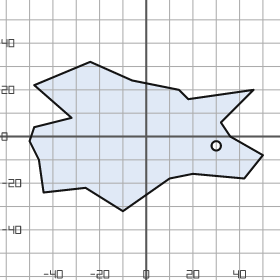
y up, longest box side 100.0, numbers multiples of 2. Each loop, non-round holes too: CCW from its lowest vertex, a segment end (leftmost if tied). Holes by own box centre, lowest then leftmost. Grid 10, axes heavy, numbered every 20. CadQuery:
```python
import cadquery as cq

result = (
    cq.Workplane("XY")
    .moveTo(-10.0, -32.0)
    .lineTo(10.0, -18.0)
    .lineTo(20.0, -16.0)
    .lineTo(42.0, -18.0)
    .lineTo(50.0, -8.0)
    .lineTo(36.0, 0.0)
    .lineTo(32.0, 6.0)
    .lineTo(46.0, 20.0)
    .lineTo(18.0, 16.0)
    .lineTo(14.0, 20.0)
    .lineTo(-6.0, 24.0)
    .lineTo(-24.0, 32.0)
    .lineTo(-48.0, 22.0)
    .lineTo(-32.0, 8.0)
    .lineTo(-48.0, 4.0)
    .lineTo(-50.0, -2.0)
    .lineTo(-46.0, -10.0)
    .lineTo(-44.0, -24.0)
    .lineTo(-26.0, -22.0)
    .close()
    .moveTo(30.0, -4.0)
    .circle(2.0)
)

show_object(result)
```